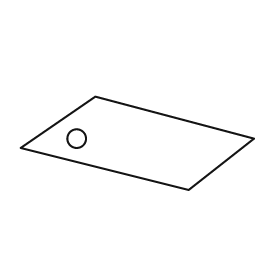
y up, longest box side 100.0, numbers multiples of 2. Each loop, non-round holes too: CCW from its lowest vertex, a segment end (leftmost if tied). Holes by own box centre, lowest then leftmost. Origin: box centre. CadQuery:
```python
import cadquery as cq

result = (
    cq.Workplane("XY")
    .moveTo(22.0, -20.0)
    .lineTo(50.0, 2.0)
    .lineTo(-18.0, 20.0)
    .lineTo(-50.0, -2.0)
    .close()
    .moveTo(-26.0, 2.0)
    .circle(4.0)
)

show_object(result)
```